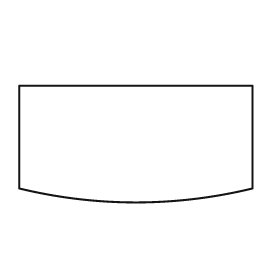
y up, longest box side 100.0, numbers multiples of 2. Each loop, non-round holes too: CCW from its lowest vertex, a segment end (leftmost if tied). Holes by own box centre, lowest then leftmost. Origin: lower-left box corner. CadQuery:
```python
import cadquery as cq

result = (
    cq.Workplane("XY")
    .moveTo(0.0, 6.0)
    .threePointArc((50.0, 0.0), (100.0, 6.0))
    .lineTo(100.0, 50.0)
    .lineTo(0.0, 50.0)
    .close()
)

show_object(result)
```